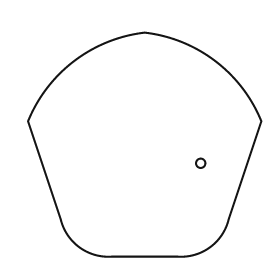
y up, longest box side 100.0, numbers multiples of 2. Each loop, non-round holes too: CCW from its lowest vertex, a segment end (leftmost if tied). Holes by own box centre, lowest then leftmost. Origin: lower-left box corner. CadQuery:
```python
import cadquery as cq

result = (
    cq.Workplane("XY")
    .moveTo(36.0, 0.0)
    .lineTo(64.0, 0.0)
    .threePointArc((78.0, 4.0), (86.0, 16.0))
    .lineTo(100.0, 58.0)
    .threePointArc((80.0, 84.0), (50.0, 96.0))
    .threePointArc((20.0, 84.0), (0.0, 58.0))
    .lineTo(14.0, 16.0)
    .threePointArc((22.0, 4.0), (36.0, 0.0))
    .close()
    .moveTo(74.0, 40.0)
    .circle(2.0)
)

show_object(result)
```